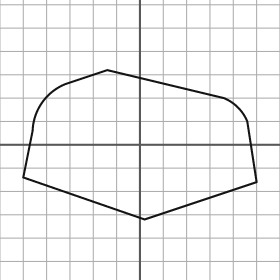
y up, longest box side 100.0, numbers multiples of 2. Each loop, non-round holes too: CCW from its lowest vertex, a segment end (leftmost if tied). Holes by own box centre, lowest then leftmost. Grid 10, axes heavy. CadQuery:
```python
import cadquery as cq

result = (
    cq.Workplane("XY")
    .moveTo(2.0, -32.0)
    .lineTo(50.0, -16.0)
    .lineTo(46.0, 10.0)
    .threePointArc((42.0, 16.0), (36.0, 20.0))
    .lineTo(-14.0, 32.0)
    .lineTo(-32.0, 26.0)
    .threePointArc((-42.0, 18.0), (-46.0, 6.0))
    .lineTo(-50.0, -14.0)
    .close()
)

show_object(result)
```